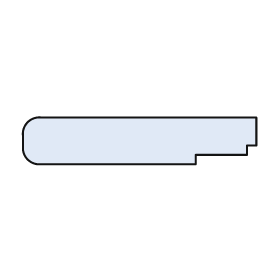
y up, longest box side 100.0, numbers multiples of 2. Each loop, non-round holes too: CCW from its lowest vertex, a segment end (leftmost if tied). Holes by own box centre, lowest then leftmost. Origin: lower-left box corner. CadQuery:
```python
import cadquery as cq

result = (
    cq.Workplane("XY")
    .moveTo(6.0, 0.0)
    .lineTo(74.0, 0.0)
    .lineTo(74.0, 4.0)
    .lineTo(96.0, 4.0)
    .lineTo(96.0, 8.0)
    .lineTo(100.0, 8.0)
    .lineTo(100.0, 20.0)
    .lineTo(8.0, 20.0)
    .threePointArc((2.0, 18.0), (0.0, 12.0))
    .lineTo(0.0, 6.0)
    .threePointArc((2.0, 2.0), (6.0, 0.0))
    .close()
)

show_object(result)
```